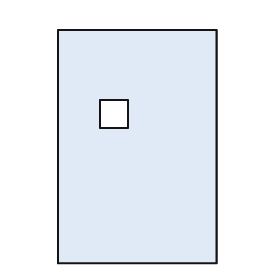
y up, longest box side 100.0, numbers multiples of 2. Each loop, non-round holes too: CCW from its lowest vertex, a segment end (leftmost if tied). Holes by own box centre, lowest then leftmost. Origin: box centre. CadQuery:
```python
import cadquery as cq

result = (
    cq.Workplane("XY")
    .moveTo(-34.0, -50.0)
    .lineTo(34.0, -50.0)
    .lineTo(34.0, 50.0)
    .lineTo(-34.0, 50.0)
    .close()
    .moveTo(-16.0, 8.0)
    .lineTo(-4.0, 8.0)
    .lineTo(-4.0, 20.0)
    .lineTo(-16.0, 20.0)
    .close()
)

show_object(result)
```